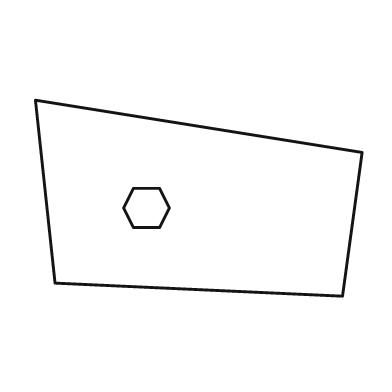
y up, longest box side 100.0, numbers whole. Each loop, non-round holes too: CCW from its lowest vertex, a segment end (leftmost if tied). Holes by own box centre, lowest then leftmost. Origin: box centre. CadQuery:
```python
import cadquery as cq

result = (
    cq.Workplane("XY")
    .moveTo(44.0, -30.0)
    .lineTo(50.0, 14.0)
    .lineTo(-50.0, 30.0)
    .lineTo(-44.0, -26.0)
    .close()
    .moveTo(-20.0, -9.0)
    .lineTo(-12.0, -9.0)
    .lineTo(-9.0, -3.0)
    .lineTo(-12.0, 3.0)
    .lineTo(-20.0, 3.0)
    .lineTo(-23.0, -3.0)
    .close()
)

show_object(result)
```